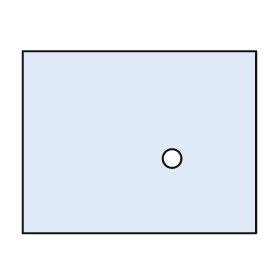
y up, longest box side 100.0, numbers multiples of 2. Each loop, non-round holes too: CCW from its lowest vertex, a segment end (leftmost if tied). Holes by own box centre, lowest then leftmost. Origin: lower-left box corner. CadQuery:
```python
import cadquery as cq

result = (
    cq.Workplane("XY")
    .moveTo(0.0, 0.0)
    .lineTo(100.0, 0.0)
    .lineTo(100.0, 78.0)
    .lineTo(0.0, 78.0)
    .close()
    .moveTo(64.0, 32.0)
    .circle(4.0)
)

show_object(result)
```